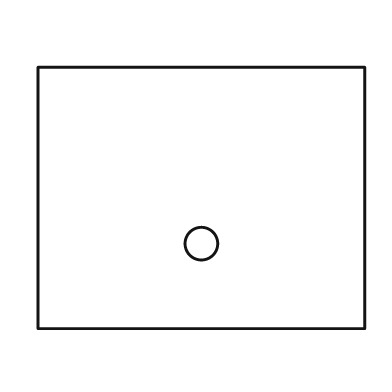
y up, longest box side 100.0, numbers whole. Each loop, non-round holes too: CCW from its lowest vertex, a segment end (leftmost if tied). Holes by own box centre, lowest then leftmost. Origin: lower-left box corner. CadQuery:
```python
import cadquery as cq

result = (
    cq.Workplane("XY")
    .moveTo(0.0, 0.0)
    .lineTo(100.0, 0.0)
    .lineTo(100.0, 80.0)
    .lineTo(0.0, 80.0)
    .close()
    .moveTo(50.0, 26.0)
    .circle(5.0)
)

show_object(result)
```